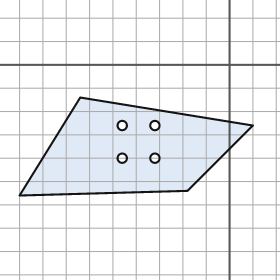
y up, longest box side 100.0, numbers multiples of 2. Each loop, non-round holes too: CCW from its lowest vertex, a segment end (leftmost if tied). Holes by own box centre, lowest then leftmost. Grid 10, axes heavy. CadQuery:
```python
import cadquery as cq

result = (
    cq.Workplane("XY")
    .moveTo(-90.0, -56.0)
    .lineTo(-18.0, -54.0)
    .lineTo(10.0, -26.0)
    .lineTo(-64.0, -14.0)
    .close()
    .moveTo(-46.0, -40.0)
    .circle(2.0)
    .moveTo(-32.0, -40.0)
    .circle(2.0)
    .moveTo(-46.0, -26.0)
    .circle(2.0)
    .moveTo(-32.0, -26.0)
    .circle(2.0)
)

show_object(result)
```